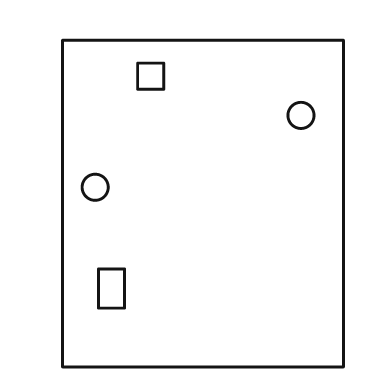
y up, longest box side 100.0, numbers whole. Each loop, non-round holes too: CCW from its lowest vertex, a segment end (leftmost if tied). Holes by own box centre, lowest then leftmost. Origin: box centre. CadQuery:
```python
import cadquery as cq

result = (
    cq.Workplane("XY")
    .moveTo(-43.0, -50.0)
    .lineTo(43.0, -50.0)
    .lineTo(43.0, 50.0)
    .lineTo(-43.0, 50.0)
    .close()
    .moveTo(-32.0, -32.0)
    .lineTo(-24.0, -32.0)
    .lineTo(-24.0, -20.0)
    .lineTo(-32.0, -20.0)
    .close()
    .moveTo(-33.0, 5.0)
    .circle(4.0)
    .moveTo(30.0, 27.0)
    .circle(4.0)
    .moveTo(-20.0, 35.0)
    .lineTo(-12.0, 35.0)
    .lineTo(-12.0, 43.0)
    .lineTo(-20.0, 43.0)
    .close()
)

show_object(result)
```